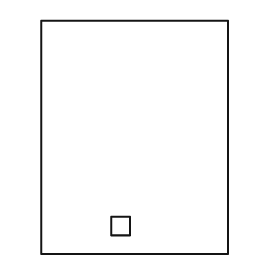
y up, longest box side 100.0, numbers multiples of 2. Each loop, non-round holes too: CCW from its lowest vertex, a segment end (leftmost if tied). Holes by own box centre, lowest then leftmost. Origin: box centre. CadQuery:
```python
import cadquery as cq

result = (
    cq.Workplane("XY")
    .moveTo(-40.0, -50.0)
    .lineTo(40.0, -50.0)
    .lineTo(40.0, 50.0)
    .lineTo(-40.0, 50.0)
    .close()
    .moveTo(-10.0, -42.0)
    .lineTo(-2.0, -42.0)
    .lineTo(-2.0, -34.0)
    .lineTo(-10.0, -34.0)
    .close()
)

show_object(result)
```